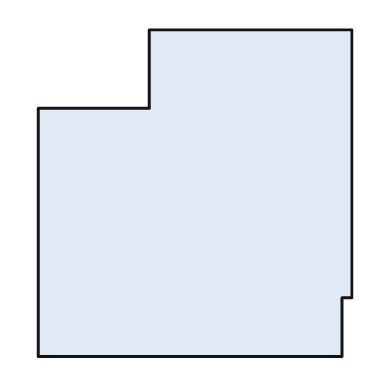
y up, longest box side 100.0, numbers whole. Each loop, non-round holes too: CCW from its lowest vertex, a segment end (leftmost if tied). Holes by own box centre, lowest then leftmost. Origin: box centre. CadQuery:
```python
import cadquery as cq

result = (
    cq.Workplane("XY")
    .moveTo(-48.0, -50.0)
    .lineTo(45.0, -50.0)
    .lineTo(45.0, -32.0)
    .lineTo(48.0, -32.0)
    .lineTo(48.0, 50.0)
    .lineTo(-14.0, 50.0)
    .lineTo(-14.0, 26.0)
    .lineTo(-48.0, 26.0)
    .close()
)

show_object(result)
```